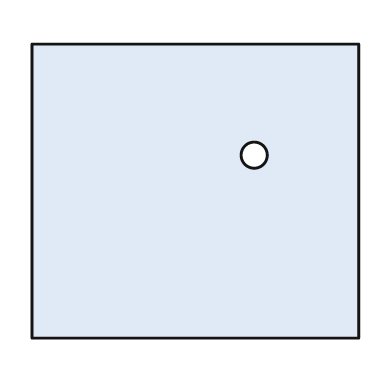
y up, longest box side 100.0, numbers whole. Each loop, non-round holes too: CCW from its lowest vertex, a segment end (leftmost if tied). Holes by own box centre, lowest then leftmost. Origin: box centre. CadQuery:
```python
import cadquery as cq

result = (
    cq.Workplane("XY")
    .moveTo(-50.0, -45.0)
    .lineTo(50.0, -45.0)
    .lineTo(50.0, 45.0)
    .lineTo(-50.0, 45.0)
    .close()
    .moveTo(18.0, 11.0)
    .circle(4.0)
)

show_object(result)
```